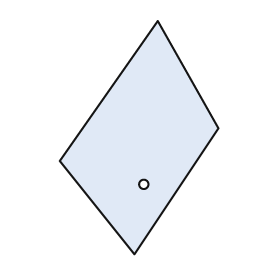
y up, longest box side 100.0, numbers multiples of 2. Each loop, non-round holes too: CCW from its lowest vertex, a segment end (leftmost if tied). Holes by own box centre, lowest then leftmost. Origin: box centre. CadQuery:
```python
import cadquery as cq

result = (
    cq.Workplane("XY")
    .moveTo(-2.0, -50.0)
    .lineTo(34.0, 4.0)
    .lineTo(8.0, 50.0)
    .lineTo(-34.0, -10.0)
    .close()
    .moveTo(2.0, -20.0)
    .circle(2.0)
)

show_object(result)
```